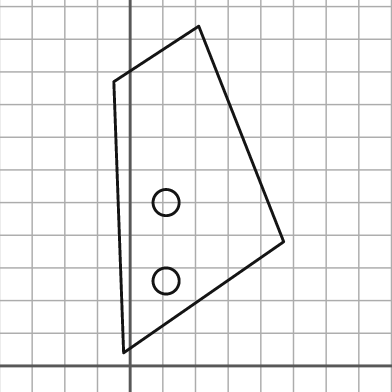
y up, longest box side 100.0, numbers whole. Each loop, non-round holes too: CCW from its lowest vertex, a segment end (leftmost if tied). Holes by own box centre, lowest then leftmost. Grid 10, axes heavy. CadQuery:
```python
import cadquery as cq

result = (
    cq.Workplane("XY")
    .moveTo(-2.0, 4.0)
    .lineTo(47.0, 38.0)
    .lineTo(21.0, 104.0)
    .lineTo(-5.0, 87.0)
    .close()
    .moveTo(11.0, 26.0)
    .circle(4.0)
    .moveTo(11.0, 50.0)
    .circle(4.0)
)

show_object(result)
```